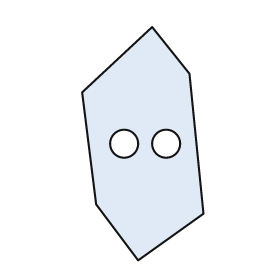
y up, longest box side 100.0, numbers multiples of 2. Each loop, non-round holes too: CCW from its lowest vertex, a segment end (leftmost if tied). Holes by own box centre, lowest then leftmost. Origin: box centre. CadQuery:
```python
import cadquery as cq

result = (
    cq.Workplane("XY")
    .moveTo(-2.0, -50.0)
    .lineTo(26.0, -30.0)
    .lineTo(20.0, 30.0)
    .lineTo(4.0, 50.0)
    .lineTo(-26.0, 22.0)
    .lineTo(-20.0, -26.0)
    .close()
    .moveTo(-8.0, 0.0)
    .circle(6.0)
    .moveTo(10.0, 0.0)
    .circle(6.0)
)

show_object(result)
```